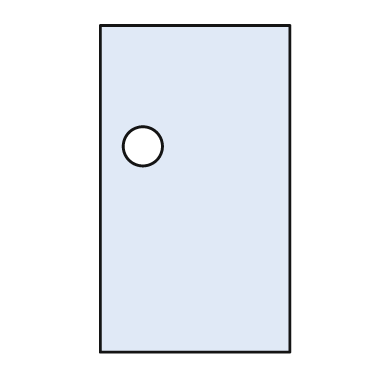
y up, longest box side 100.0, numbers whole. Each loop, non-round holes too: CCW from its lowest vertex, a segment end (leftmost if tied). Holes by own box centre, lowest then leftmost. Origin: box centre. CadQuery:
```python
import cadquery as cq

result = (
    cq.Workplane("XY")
    .moveTo(-29.0, -50.0)
    .lineTo(29.0, -50.0)
    .lineTo(29.0, 50.0)
    .lineTo(-29.0, 50.0)
    .close()
    .moveTo(-16.0, 13.0)
    .circle(6.0)
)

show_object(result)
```